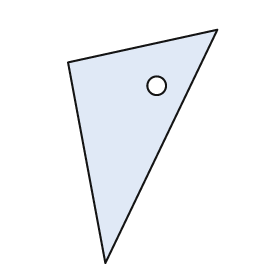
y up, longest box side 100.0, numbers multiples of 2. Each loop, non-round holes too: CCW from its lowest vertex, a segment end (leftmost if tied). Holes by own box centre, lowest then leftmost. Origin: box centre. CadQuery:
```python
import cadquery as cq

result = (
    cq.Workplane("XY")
    .moveTo(-16.0, -50.0)
    .lineTo(32.0, 50.0)
    .lineTo(-32.0, 36.0)
    .close()
    .moveTo(6.0, 26.0)
    .circle(4.0)
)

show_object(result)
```